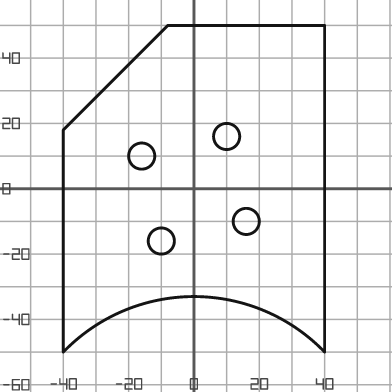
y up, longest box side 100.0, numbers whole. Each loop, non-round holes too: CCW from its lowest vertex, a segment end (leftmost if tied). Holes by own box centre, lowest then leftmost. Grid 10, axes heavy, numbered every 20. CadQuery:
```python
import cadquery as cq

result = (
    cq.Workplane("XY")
    .moveTo(-40.0, -50.0)
    .threePointArc((0.0, -33.0), (40.0, -50.0))
    .lineTo(40.0, 50.0)
    .lineTo(-8.0, 50.0)
    .lineTo(-40.0, 18.0)
    .close()
    .moveTo(-10.0, -16.0)
    .circle(4.0)
    .moveTo(16.0, -10.0)
    .circle(4.0)
    .moveTo(-16.0, 10.0)
    .circle(4.0)
    .moveTo(10.0, 16.0)
    .circle(4.0)
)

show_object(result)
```